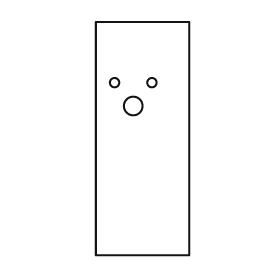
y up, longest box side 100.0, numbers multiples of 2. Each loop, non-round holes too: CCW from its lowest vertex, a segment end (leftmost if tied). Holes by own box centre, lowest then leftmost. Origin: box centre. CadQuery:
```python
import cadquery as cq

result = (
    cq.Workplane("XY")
    .moveTo(-20.0, -50.0)
    .lineTo(20.0, -50.0)
    .lineTo(20.0, 50.0)
    .lineTo(-20.0, 50.0)
    .close()
    .moveTo(-4.0, 14.0)
    .circle(4.0)
    .moveTo(-12.0, 24.0)
    .circle(2.0)
    .moveTo(4.0, 24.0)
    .circle(2.0)
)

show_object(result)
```